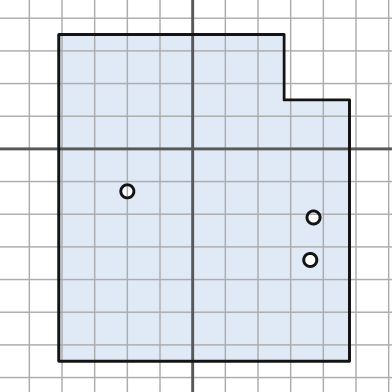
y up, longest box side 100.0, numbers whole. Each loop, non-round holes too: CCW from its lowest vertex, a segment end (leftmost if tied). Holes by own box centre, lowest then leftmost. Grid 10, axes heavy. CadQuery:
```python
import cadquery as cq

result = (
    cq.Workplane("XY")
    .moveTo(-41.0, -65.0)
    .lineTo(48.0, -65.0)
    .lineTo(48.0, 15.0)
    .lineTo(28.0, 15.0)
    .lineTo(28.0, 35.0)
    .lineTo(-41.0, 35.0)
    .close()
    .moveTo(36.0, -34.0)
    .circle(2.0)
    .moveTo(37.0, -21.0)
    .circle(2.0)
    .moveTo(-20.0, -13.0)
    .circle(2.0)
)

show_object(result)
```